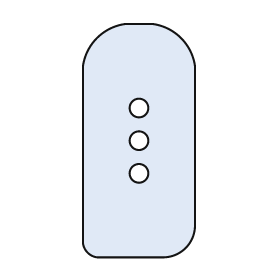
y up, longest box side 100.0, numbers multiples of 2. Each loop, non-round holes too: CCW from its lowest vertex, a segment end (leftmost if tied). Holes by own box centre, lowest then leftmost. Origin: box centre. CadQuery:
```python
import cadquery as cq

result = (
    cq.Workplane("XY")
    .moveTo(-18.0, -50.0)
    .lineTo(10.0, -50.0)
    .threePointArc((20.0, -46.0), (24.0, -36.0))
    .lineTo(24.0, 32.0)
    .threePointArc((18.0, 44.0), (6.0, 50.0))
    .lineTo(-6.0, 50.0)
    .threePointArc((-18.0, 44.0), (-24.0, 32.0))
    .lineTo(-24.0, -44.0)
    .threePointArc((-22.0, -48.0), (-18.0, -50.0))
    .close()
    .moveTo(0.0, -14.0)
    .circle(4.0)
    .moveTo(0.0, 0.0)
    .circle(4.0)
    .moveTo(0.0, 14.0)
    .circle(4.0)
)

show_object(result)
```